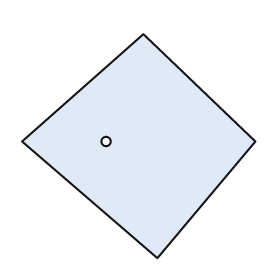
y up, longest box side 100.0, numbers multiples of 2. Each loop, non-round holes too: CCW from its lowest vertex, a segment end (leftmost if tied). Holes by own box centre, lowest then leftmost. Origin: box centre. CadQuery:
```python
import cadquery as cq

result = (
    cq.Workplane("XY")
    .moveTo(8.0, -48.0)
    .lineTo(50.0, 2.0)
    .lineTo(2.0, 48.0)
    .lineTo(-50.0, 2.0)
    .close()
    .moveTo(-14.0, 2.0)
    .circle(2.0)
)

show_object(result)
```